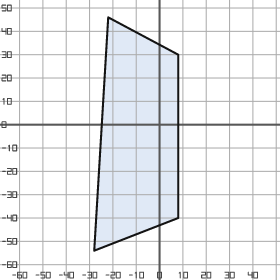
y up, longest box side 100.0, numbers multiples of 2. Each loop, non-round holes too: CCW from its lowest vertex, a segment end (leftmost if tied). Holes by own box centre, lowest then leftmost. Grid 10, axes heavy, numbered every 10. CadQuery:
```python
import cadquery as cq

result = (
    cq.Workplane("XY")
    .moveTo(-28.0, -54.0)
    .lineTo(8.0, -40.0)
    .lineTo(8.0, 30.0)
    .lineTo(-22.0, 46.0)
    .close()
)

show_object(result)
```